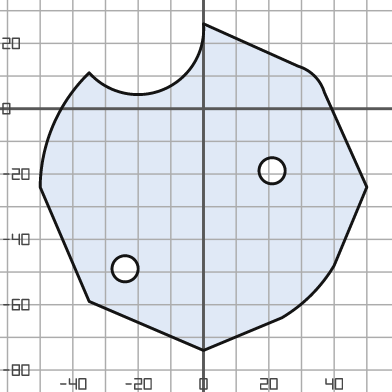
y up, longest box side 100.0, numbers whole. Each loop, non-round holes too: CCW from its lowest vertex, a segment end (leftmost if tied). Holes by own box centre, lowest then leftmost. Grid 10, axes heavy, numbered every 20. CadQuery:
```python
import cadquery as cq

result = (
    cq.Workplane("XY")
    .moveTo(0.0, -74.0)
    .lineTo(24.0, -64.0)
    .threePointArc((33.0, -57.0), (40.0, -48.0))
    .lineTo(50.0, -24.0)
    .lineTo(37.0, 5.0)
    .threePointArc((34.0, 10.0), (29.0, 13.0))
    .lineTo(0.0, 26.0)
    .threePointArc((-12.0, 6.0), (-35.0, 11.0))
    .threePointArc((-46.0, -5.0), (-50.0, -24.0))
    .lineTo(-35.0, -59.0)
    .close()
    .moveTo(-24.0, -49.0)
    .circle(4.0)
    .moveTo(21.0, -19.0)
    .circle(4.0)
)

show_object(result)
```